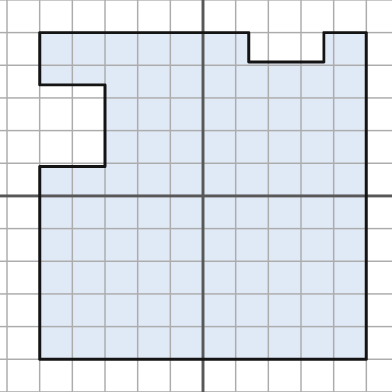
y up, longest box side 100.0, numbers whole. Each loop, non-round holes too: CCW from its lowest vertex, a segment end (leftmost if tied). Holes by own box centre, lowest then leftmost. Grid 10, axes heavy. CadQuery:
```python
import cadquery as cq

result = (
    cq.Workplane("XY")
    .moveTo(-50.0, -50.0)
    .lineTo(50.0, -50.0)
    .lineTo(50.0, 50.0)
    .lineTo(37.0, 50.0)
    .lineTo(37.0, 41.0)
    .lineTo(14.0, 41.0)
    .lineTo(14.0, 50.0)
    .lineTo(-50.0, 50.0)
    .lineTo(-50.0, 34.0)
    .lineTo(-30.0, 34.0)
    .lineTo(-30.0, 9.0)
    .lineTo(-50.0, 9.0)
    .close()
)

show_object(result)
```